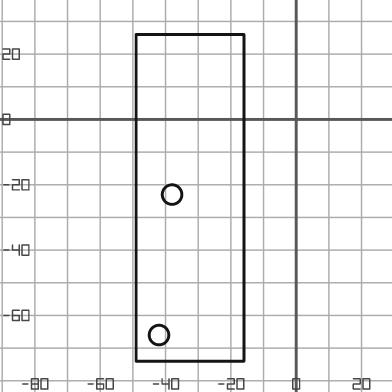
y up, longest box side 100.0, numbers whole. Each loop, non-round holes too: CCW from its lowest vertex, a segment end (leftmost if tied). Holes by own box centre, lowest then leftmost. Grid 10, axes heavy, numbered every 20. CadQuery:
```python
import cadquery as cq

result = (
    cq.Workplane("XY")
    .moveTo(-49.0, -74.0)
    .lineTo(-16.0, -74.0)
    .lineTo(-16.0, 26.0)
    .lineTo(-49.0, 26.0)
    .close()
    .moveTo(-42.0, -66.0)
    .circle(3.0)
    .moveTo(-38.0, -23.0)
    .circle(3.0)
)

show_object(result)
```